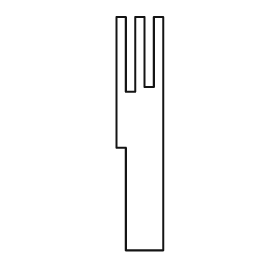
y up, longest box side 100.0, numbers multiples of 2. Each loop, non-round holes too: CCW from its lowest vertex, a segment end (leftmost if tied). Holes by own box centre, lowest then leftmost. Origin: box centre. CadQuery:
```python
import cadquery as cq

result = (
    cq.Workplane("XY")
    .moveTo(-6.0, -50.0)
    .lineTo(10.0, -50.0)
    .lineTo(10.0, 50.0)
    .lineTo(6.0, 50.0)
    .lineTo(6.0, 20.0)
    .lineTo(2.0, 20.0)
    .lineTo(2.0, 50.0)
    .lineTo(-2.0, 50.0)
    .lineTo(-2.0, 18.0)
    .lineTo(-6.0, 18.0)
    .lineTo(-6.0, 50.0)
    .lineTo(-10.0, 50.0)
    .lineTo(-10.0, -6.0)
    .lineTo(-6.0, -6.0)
    .close()
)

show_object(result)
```